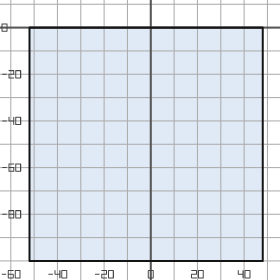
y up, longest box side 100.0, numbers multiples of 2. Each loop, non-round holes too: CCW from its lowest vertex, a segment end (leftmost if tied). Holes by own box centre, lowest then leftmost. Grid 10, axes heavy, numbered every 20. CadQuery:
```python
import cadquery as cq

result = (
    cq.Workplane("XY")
    .moveTo(-52.0, -100.0)
    .lineTo(48.0, -100.0)
    .lineTo(48.0, 0.0)
    .lineTo(-52.0, 0.0)
    .close()
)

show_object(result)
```